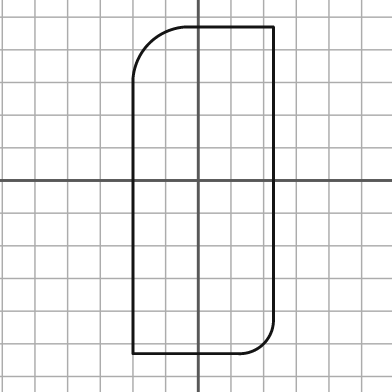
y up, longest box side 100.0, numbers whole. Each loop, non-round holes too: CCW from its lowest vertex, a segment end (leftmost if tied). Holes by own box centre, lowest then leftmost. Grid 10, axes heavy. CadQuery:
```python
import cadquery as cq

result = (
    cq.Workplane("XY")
    .moveTo(-20.0, -53.0)
    .lineTo(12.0, -53.0)
    .threePointArc((20.0, -50.0), (23.0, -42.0))
    .lineTo(23.0, 47.0)
    .lineTo(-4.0, 47.0)
    .threePointArc((-15.0, 42.0), (-20.0, 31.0))
    .close()
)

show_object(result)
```